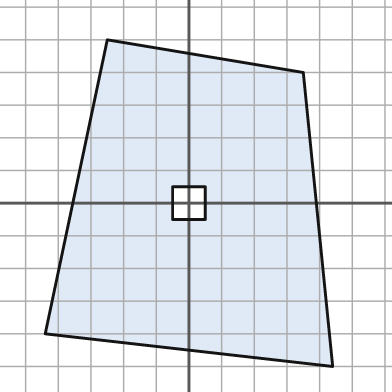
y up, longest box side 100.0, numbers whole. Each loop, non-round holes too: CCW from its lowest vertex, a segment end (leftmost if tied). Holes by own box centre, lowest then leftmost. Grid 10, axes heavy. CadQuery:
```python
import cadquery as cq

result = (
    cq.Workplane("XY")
    .moveTo(44.0, -50.0)
    .lineTo(35.0, 40.0)
    .lineTo(-25.0, 50.0)
    .lineTo(-44.0, -40.0)
    .close()
    .moveTo(-5.0, -5.0)
    .lineTo(5.0, -5.0)
    .lineTo(5.0, 5.0)
    .lineTo(-5.0, 5.0)
    .close()
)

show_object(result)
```